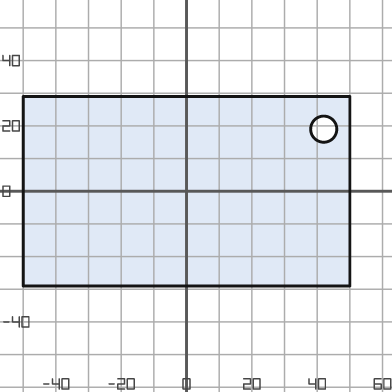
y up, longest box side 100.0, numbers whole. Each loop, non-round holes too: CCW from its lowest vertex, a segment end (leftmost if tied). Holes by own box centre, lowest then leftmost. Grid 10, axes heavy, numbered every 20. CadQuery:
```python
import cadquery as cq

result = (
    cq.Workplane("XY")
    .moveTo(-50.0, -29.0)
    .lineTo(50.0, -29.0)
    .lineTo(50.0, 29.0)
    .lineTo(-50.0, 29.0)
    .close()
    .moveTo(42.0, 19.0)
    .circle(4.0)
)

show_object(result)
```